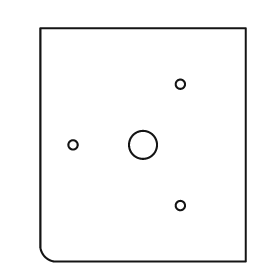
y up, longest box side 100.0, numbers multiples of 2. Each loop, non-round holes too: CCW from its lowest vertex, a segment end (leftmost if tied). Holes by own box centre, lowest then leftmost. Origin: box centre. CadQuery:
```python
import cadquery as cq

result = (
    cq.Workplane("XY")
    .moveTo(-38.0, -50.0)
    .lineTo(44.0, -50.0)
    .lineTo(44.0, 50.0)
    .lineTo(-44.0, 50.0)
    .lineTo(-44.0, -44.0)
    .threePointArc((-42.0, -48.0), (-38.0, -50.0))
    .close()
    .moveTo(16.0, -26.0)
    .circle(2.0)
    .moveTo(-30.0, 0.0)
    .circle(2.0)
    .moveTo(0.0, 0.0)
    .circle(6.0)
    .moveTo(16.0, 26.0)
    .circle(2.0)
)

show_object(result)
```